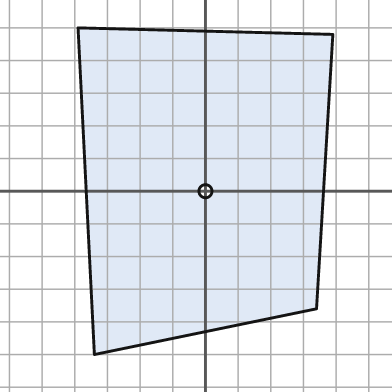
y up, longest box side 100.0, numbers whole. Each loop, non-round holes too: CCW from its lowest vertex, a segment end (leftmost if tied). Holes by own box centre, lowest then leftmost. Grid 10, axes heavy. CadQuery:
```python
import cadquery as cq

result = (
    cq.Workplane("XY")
    .moveTo(-34.0, -50.0)
    .lineTo(34.0, -36.0)
    .lineTo(39.0, 48.0)
    .lineTo(-39.0, 50.0)
    .close()
    .moveTo(0.0, 0.0)
    .circle(2.0)
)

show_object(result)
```